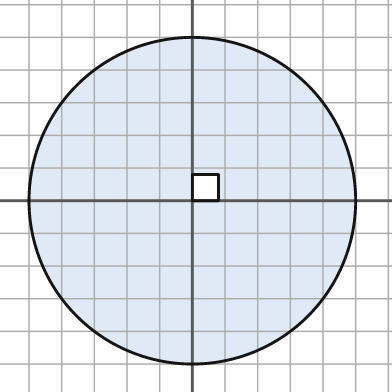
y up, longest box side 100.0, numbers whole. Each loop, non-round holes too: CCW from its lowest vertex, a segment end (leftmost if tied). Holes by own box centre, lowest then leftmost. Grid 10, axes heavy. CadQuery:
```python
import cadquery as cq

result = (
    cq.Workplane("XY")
    .moveTo(0.0, 0.0)
    .circle(50.0)
    .moveTo(0.0, 0.0)
    .lineTo(8.0, 0.0)
    .lineTo(8.0, 8.0)
    .lineTo(0.0, 8.0)
    .close()
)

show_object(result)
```